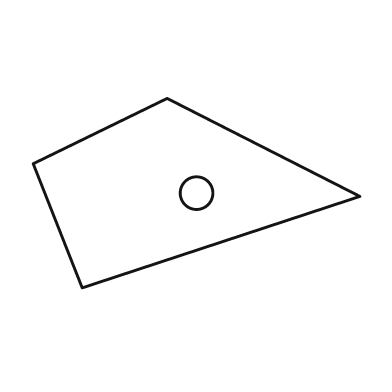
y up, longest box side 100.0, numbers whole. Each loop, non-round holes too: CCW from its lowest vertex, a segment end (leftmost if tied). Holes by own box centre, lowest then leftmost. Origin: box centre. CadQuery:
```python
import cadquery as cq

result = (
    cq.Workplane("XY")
    .moveTo(-35.0, -29.0)
    .lineTo(50.0, -1.0)
    .lineTo(-9.0, 29.0)
    .lineTo(-50.0, 9.0)
    .close()
    .moveTo(0.0, 0.0)
    .circle(5.0)
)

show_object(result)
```